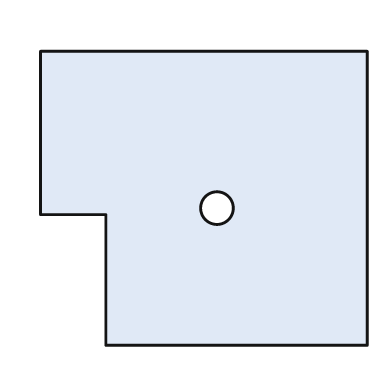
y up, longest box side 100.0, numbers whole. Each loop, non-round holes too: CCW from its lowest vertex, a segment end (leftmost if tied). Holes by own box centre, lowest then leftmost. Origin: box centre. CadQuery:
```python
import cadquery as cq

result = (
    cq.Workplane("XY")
    .moveTo(-30.0, -45.0)
    .lineTo(50.0, -45.0)
    .lineTo(50.0, 45.0)
    .lineTo(-50.0, 45.0)
    .lineTo(-50.0, -5.0)
    .lineTo(-30.0, -5.0)
    .close()
    .moveTo(4.0, -3.0)
    .circle(5.0)
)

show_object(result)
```